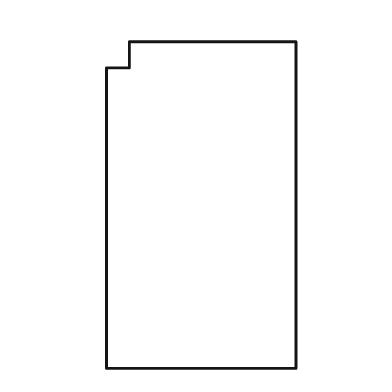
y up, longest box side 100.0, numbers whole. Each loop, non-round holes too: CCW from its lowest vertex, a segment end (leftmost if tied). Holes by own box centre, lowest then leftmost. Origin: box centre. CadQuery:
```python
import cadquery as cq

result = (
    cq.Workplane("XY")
    .moveTo(-29.0, -50.0)
    .lineTo(29.0, -50.0)
    .lineTo(29.0, 50.0)
    .lineTo(-22.0, 50.0)
    .lineTo(-22.0, 42.0)
    .lineTo(-29.0, 42.0)
    .close()
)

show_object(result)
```